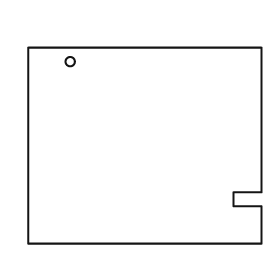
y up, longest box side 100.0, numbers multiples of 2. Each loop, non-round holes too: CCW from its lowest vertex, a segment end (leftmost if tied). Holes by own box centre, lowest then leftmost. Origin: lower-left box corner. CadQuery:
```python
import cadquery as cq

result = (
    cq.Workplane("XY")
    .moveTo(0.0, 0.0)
    .lineTo(100.0, 0.0)
    .lineTo(100.0, 16.0)
    .lineTo(88.0, 16.0)
    .lineTo(88.0, 22.0)
    .lineTo(100.0, 22.0)
    .lineTo(100.0, 84.0)
    .lineTo(0.0, 84.0)
    .close()
    .moveTo(18.0, 78.0)
    .circle(2.0)
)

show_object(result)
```